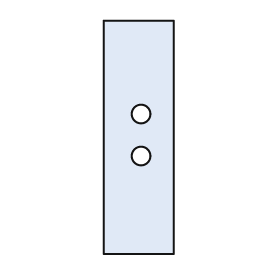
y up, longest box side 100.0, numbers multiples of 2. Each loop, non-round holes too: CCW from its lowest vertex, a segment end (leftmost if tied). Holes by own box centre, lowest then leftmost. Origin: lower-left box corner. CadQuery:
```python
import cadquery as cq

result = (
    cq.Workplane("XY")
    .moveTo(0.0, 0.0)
    .lineTo(30.0, 0.0)
    .lineTo(30.0, 100.0)
    .lineTo(0.0, 100.0)
    .close()
    .moveTo(16.0, 42.0)
    .circle(4.0)
    .moveTo(16.0, 60.0)
    .circle(4.0)
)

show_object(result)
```